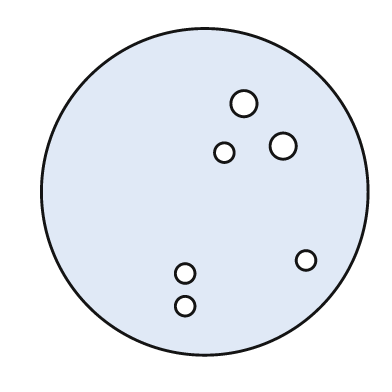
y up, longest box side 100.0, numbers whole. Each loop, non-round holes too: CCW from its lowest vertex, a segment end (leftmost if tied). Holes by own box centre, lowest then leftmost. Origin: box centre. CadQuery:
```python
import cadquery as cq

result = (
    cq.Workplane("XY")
    .moveTo(0.0, 0.0)
    .circle(50.0)
    .moveTo(-6.0, -35.0)
    .circle(3.0)
    .moveTo(-6.0, -25.0)
    .circle(3.0)
    .moveTo(31.0, -21.0)
    .circle(3.0)
    .moveTo(6.0, 12.0)
    .circle(3.0)
    .moveTo(24.0, 14.0)
    .circle(4.0)
    .moveTo(12.0, 27.0)
    .circle(4.0)
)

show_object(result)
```